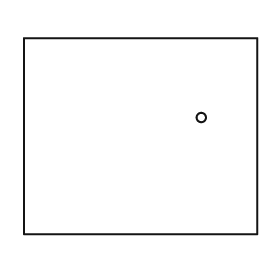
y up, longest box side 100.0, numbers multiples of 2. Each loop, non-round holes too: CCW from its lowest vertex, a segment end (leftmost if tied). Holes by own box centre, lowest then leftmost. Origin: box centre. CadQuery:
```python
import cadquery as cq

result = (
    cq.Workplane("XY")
    .moveTo(-50.0, -42.0)
    .lineTo(50.0, -42.0)
    .lineTo(50.0, 42.0)
    .lineTo(-50.0, 42.0)
    .close()
    .moveTo(26.0, 8.0)
    .circle(2.0)
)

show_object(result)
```